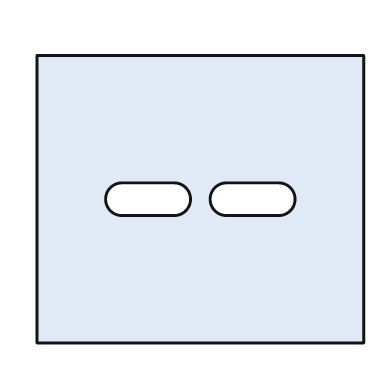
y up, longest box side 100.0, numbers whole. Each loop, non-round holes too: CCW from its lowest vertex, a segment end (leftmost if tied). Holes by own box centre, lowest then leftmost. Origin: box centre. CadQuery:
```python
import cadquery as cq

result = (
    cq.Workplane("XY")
    .moveTo(-50.0, -44.0)
    .lineTo(50.0, -44.0)
    .lineTo(50.0, 44.0)
    .lineTo(-50.0, 44.0)
    .close()
    .moveTo(-24.0, -5.0)
    .lineTo(-8.0, -5.0)
    .threePointArc((-3.0, 0.0), (-8.0, 5.0))
    .lineTo(-24.0, 5.0)
    .threePointArc((-29.0, 0.0), (-24.0, -5.0))
    .close()
    .moveTo(8.0, -5.0)
    .lineTo(24.0, -5.0)
    .threePointArc((29.0, 0.0), (24.0, 5.0))
    .lineTo(8.0, 5.0)
    .threePointArc((3.0, 0.0), (8.0, -5.0))
    .close()
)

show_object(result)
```